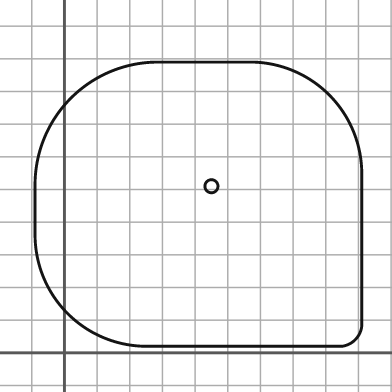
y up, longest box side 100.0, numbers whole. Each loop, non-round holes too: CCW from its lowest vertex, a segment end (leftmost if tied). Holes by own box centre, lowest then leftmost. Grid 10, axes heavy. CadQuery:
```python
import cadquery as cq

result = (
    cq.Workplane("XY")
    .moveTo(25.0, 2.0)
    .lineTo(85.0, 2.0)
    .threePointArc((89.0, 4.0), (91.0, 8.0))
    .lineTo(91.0, 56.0)
    .threePointArc((81.0, 79.0), (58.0, 89.0))
    .lineTo(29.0, 89.0)
    .threePointArc((2.0, 78.0), (-9.0, 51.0))
    .lineTo(-9.0, 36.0)
    .threePointArc((1.0, 12.0), (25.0, 2.0))
    .close()
    .moveTo(45.0, 51.0)
    .circle(2.0)
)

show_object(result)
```